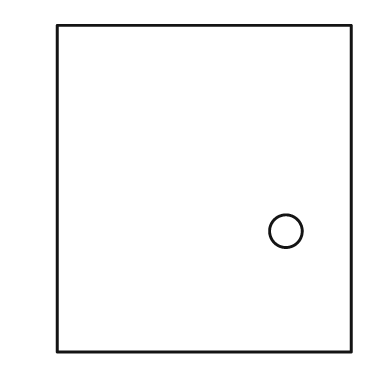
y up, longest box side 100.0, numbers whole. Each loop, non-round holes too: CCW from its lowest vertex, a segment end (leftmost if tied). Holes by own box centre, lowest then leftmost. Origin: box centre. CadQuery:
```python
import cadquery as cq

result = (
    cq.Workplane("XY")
    .moveTo(-45.0, -50.0)
    .lineTo(45.0, -50.0)
    .lineTo(45.0, 50.0)
    .lineTo(-45.0, 50.0)
    .close()
    .moveTo(25.0, -13.0)
    .circle(5.0)
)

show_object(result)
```